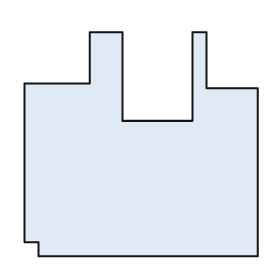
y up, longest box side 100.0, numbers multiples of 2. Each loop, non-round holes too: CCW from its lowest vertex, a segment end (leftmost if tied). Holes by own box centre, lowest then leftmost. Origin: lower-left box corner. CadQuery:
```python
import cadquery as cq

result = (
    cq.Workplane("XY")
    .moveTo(6.0, 0.0)
    .lineTo(100.0, 0.0)
    .lineTo(100.0, 72.0)
    .lineTo(78.0, 72.0)
    .lineTo(78.0, 96.0)
    .lineTo(72.0, 96.0)
    .lineTo(72.0, 58.0)
    .lineTo(42.0, 58.0)
    .lineTo(42.0, 96.0)
    .lineTo(28.0, 96.0)
    .lineTo(28.0, 74.0)
    .lineTo(0.0, 74.0)
    .lineTo(0.0, 6.0)
    .lineTo(6.0, 6.0)
    .close()
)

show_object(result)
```